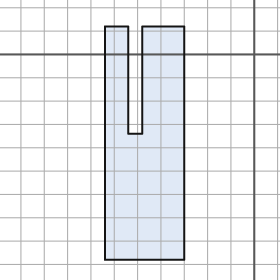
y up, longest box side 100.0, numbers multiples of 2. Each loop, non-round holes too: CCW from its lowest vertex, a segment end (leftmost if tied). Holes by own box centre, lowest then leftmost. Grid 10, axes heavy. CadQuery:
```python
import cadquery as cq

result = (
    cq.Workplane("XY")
    .moveTo(-64.0, -88.0)
    .lineTo(-30.0, -88.0)
    .lineTo(-30.0, 12.0)
    .lineTo(-48.0, 12.0)
    .lineTo(-48.0, -34.0)
    .lineTo(-54.0, -34.0)
    .lineTo(-54.0, 12.0)
    .lineTo(-64.0, 12.0)
    .close()
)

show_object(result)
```